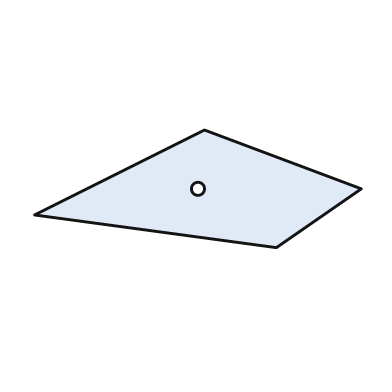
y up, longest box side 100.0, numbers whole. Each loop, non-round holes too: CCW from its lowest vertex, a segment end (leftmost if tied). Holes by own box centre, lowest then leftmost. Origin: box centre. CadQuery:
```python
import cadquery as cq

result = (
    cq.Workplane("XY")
    .moveTo(24.0, -18.0)
    .lineTo(50.0, 0.0)
    .lineTo(2.0, 18.0)
    .lineTo(-50.0, -8.0)
    .close()
    .moveTo(0.0, 0.0)
    .circle(2.0)
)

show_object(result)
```